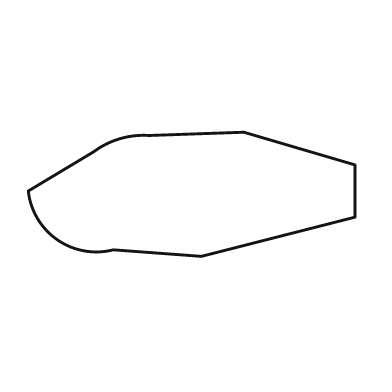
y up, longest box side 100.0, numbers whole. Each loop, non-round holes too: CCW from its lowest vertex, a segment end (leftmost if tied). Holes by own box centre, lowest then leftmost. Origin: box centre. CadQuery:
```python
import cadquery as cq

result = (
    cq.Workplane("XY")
    .moveTo(3.0, -19.0)
    .lineTo(50.0, -7.0)
    .lineTo(50.0, 9.0)
    .lineTo(16.0, 19.0)
    .lineTo(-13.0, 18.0)
    .threePointArc((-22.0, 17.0), (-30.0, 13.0))
    .lineTo(-50.0, 1.0)
    .threePointArc((-41.0, -14.0), (-24.0, -17.0))
    .close()
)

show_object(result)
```